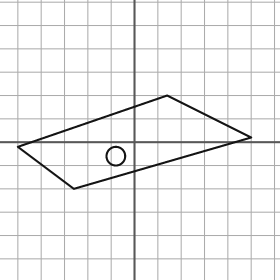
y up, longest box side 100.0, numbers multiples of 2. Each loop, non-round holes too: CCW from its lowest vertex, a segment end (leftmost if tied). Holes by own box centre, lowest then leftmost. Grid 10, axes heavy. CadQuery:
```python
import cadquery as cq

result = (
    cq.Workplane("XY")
    .moveTo(-26.0, -20.0)
    .lineTo(50.0, 2.0)
    .lineTo(14.0, 20.0)
    .lineTo(-50.0, -2.0)
    .close()
    .moveTo(-8.0, -6.0)
    .circle(4.0)
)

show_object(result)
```